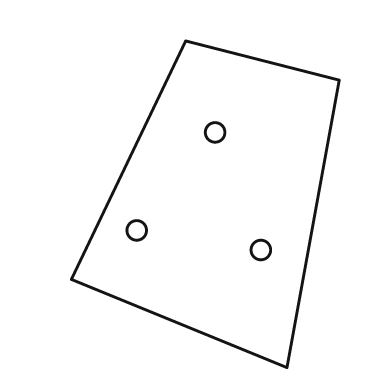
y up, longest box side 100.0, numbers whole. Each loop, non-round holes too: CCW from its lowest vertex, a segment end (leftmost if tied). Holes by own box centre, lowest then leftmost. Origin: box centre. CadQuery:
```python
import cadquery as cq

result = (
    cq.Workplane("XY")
    .moveTo(25.0, -50.0)
    .lineTo(41.0, 38.0)
    .lineTo(-6.0, 50.0)
    .lineTo(-41.0, -23.0)
    .close()
    .moveTo(17.0, -14.0)
    .circle(3.0)
    .moveTo(-21.0, -8.0)
    .circle(3.0)
    .moveTo(3.0, 22.0)
    .circle(3.0)
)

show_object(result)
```